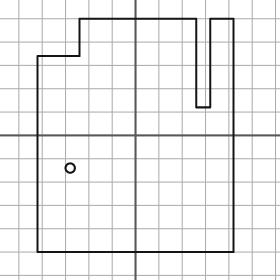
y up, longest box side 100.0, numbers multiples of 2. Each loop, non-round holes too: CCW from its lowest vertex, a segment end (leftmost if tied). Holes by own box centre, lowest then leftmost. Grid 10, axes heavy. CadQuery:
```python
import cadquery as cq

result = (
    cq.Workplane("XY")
    .moveTo(-42.0, -50.0)
    .lineTo(42.0, -50.0)
    .lineTo(42.0, 50.0)
    .lineTo(32.0, 50.0)
    .lineTo(32.0, 12.0)
    .lineTo(26.0, 12.0)
    .lineTo(26.0, 50.0)
    .lineTo(-24.0, 50.0)
    .lineTo(-24.0, 34.0)
    .lineTo(-42.0, 34.0)
    .close()
    .moveTo(-28.0, -14.0)
    .circle(2.0)
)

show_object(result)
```